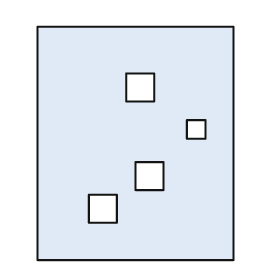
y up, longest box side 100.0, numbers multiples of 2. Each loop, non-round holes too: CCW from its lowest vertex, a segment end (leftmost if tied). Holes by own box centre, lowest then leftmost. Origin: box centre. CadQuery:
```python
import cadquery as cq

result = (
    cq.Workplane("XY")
    .moveTo(-42.0, -50.0)
    .lineTo(42.0, -50.0)
    .lineTo(42.0, 50.0)
    .lineTo(-42.0, 50.0)
    .close()
    .moveTo(-20.0, -34.0)
    .lineTo(-8.0, -34.0)
    .lineTo(-8.0, -22.0)
    .lineTo(-20.0, -22.0)
    .close()
    .moveTo(0.0, -20.0)
    .lineTo(12.0, -20.0)
    .lineTo(12.0, -8.0)
    .lineTo(0.0, -8.0)
    .close()
    .moveTo(22.0, 2.0)
    .lineTo(30.0, 2.0)
    .lineTo(30.0, 10.0)
    .lineTo(22.0, 10.0)
    .close()
    .moveTo(-4.0, 18.0)
    .lineTo(8.0, 18.0)
    .lineTo(8.0, 30.0)
    .lineTo(-4.0, 30.0)
    .close()
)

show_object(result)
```